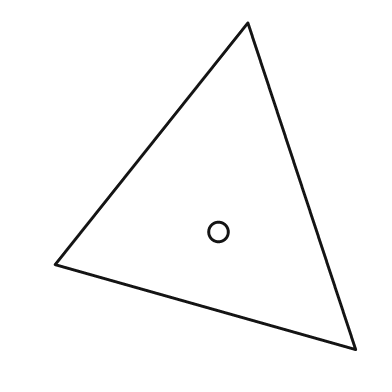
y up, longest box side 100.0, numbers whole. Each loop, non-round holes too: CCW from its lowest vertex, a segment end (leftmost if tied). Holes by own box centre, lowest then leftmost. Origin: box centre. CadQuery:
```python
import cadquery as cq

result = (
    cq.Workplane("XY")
    .moveTo(46.0, -50.0)
    .lineTo(13.0, 50.0)
    .lineTo(-46.0, -24.0)
    .close()
    .moveTo(4.0, -14.0)
    .circle(3.0)
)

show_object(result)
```